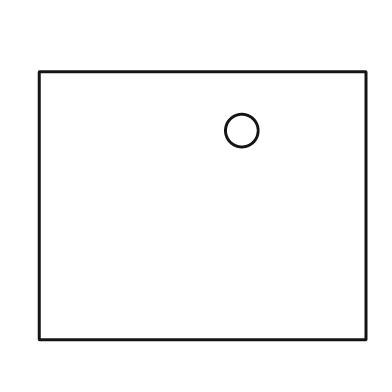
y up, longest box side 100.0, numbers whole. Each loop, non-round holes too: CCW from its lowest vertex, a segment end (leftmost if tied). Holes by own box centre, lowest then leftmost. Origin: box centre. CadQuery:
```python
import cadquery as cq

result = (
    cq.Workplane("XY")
    .moveTo(-50.0, -41.0)
    .lineTo(50.0, -41.0)
    .lineTo(50.0, 41.0)
    .lineTo(-50.0, 41.0)
    .close()
    .moveTo(12.0, 23.0)
    .circle(5.0)
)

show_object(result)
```